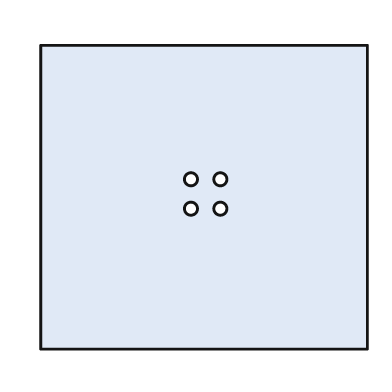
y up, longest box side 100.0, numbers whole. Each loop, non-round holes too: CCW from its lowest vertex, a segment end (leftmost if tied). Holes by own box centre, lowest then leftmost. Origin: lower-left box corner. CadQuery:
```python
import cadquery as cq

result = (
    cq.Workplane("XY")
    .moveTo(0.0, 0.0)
    .lineTo(100.0, 0.0)
    .lineTo(100.0, 93.0)
    .lineTo(0.0, 93.0)
    .close()
    .moveTo(46.0, 43.0)
    .circle(2.0)
    .moveTo(55.0, 43.0)
    .circle(2.0)
    .moveTo(46.0, 52.0)
    .circle(2.0)
    .moveTo(55.0, 52.0)
    .circle(2.0)
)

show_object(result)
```